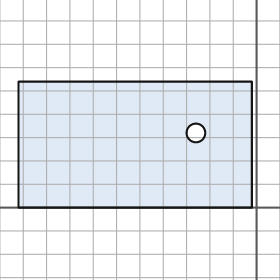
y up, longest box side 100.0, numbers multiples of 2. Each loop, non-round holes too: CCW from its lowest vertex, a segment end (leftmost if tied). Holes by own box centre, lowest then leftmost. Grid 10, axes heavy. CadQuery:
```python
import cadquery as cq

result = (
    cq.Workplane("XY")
    .moveTo(-102.0, 0.0)
    .lineTo(-2.0, 0.0)
    .lineTo(-2.0, 54.0)
    .lineTo(-102.0, 54.0)
    .close()
    .moveTo(-26.0, 32.0)
    .circle(4.0)
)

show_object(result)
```